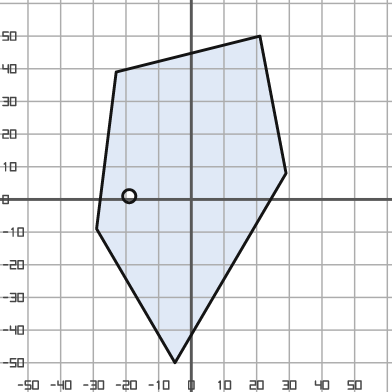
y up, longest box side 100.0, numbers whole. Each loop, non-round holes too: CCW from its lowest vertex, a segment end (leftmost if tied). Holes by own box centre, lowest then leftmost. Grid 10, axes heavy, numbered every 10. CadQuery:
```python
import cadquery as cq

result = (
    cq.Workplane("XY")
    .moveTo(-5.0, -50.0)
    .lineTo(29.0, 8.0)
    .lineTo(21.0, 50.0)
    .lineTo(-23.0, 39.0)
    .lineTo(-29.0, -9.0)
    .close()
    .moveTo(-19.0, 1.0)
    .circle(2.0)
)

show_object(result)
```